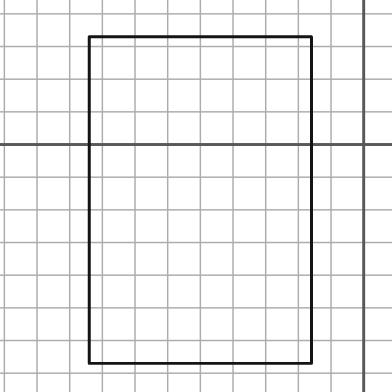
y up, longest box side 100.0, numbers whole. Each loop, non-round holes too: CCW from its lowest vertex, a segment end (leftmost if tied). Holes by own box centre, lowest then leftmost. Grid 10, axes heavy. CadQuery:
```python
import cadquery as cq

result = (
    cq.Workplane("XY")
    .moveTo(-84.0, -67.0)
    .lineTo(-16.0, -67.0)
    .lineTo(-16.0, 33.0)
    .lineTo(-84.0, 33.0)
    .close()
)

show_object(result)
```